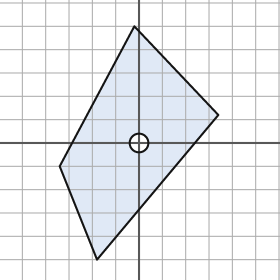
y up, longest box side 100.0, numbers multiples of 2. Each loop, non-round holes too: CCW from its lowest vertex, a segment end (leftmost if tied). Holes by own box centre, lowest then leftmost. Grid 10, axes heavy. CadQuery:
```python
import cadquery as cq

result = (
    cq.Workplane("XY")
    .moveTo(-18.0, -50.0)
    .lineTo(34.0, 12.0)
    .lineTo(-2.0, 50.0)
    .lineTo(-34.0, -10.0)
    .close()
    .moveTo(0.0, 0.0)
    .circle(4.0)
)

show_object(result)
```